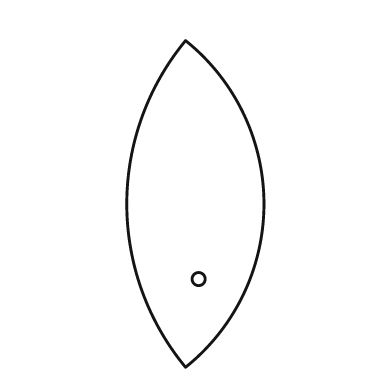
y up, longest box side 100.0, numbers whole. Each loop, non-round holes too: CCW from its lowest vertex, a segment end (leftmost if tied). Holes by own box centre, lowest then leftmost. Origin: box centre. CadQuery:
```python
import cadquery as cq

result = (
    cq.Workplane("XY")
    .moveTo(-3.0, -50.0)
    .threePointArc((21.0, 0.0), (-3.0, 50.0))
    .threePointArc((-21.0, 0.0), (-3.0, -50.0))
    .close()
    .moveTo(1.0, -23.0)
    .circle(2.0)
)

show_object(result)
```